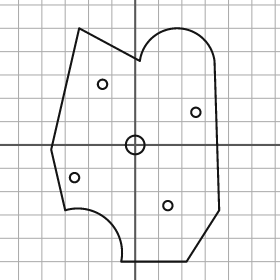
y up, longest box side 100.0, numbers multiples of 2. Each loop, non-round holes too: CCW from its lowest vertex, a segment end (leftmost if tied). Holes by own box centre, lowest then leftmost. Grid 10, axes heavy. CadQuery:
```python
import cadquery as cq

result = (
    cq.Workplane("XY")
    .moveTo(-6.0, -50.0)
    .lineTo(22.0, -50.0)
    .lineTo(36.0, -28.0)
    .lineTo(34.0, 36.0)
    .threePointArc((18.0, 50.0), (2.0, 36.0))
    .lineTo(-24.0, 50.0)
    .lineTo(-36.0, -2.0)
    .lineTo(-30.0, -28.0)
    .threePointArc((-12.0, -32.0), (-6.0, -50.0))
    .close()
    .moveTo(14.0, -26.0)
    .circle(2.0)
    .moveTo(-26.0, -14.0)
    .circle(2.0)
    .moveTo(0.0, 0.0)
    .circle(4.0)
    .moveTo(26.0, 14.0)
    .circle(2.0)
    .moveTo(-14.0, 26.0)
    .circle(2.0)
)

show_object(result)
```